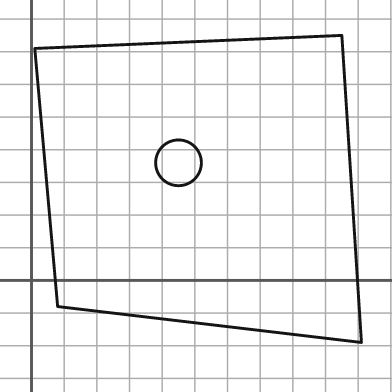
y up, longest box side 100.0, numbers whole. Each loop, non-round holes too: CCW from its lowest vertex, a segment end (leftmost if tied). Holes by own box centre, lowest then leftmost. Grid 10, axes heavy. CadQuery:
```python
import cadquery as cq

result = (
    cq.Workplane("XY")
    .moveTo(101.0, -19.0)
    .lineTo(95.0, 75.0)
    .lineTo(1.0, 71.0)
    .lineTo(8.0, -8.0)
    .close()
    .moveTo(45.0, 36.0)
    .circle(7.0)
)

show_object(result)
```